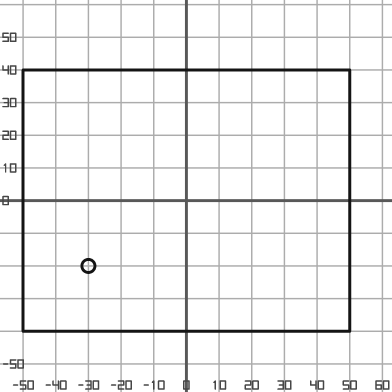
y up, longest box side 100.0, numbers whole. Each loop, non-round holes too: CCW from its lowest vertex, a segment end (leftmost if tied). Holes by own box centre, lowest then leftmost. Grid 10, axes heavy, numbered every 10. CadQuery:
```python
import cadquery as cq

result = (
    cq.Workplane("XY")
    .moveTo(-50.0, -40.0)
    .lineTo(50.0, -40.0)
    .lineTo(50.0, 40.0)
    .lineTo(-50.0, 40.0)
    .close()
    .moveTo(-30.0, -20.0)
    .circle(2.0)
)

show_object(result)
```